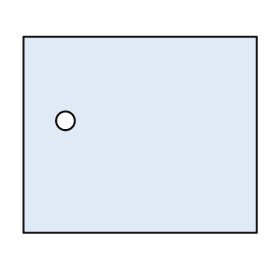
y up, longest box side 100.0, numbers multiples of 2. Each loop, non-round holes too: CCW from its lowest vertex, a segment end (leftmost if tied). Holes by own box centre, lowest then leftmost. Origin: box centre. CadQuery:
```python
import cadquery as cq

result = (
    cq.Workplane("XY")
    .moveTo(-50.0, -42.0)
    .lineTo(50.0, -42.0)
    .lineTo(50.0, 42.0)
    .lineTo(-50.0, 42.0)
    .close()
    .moveTo(-32.0, 6.0)
    .circle(4.0)
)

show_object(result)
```